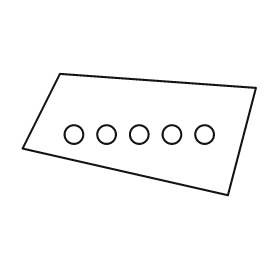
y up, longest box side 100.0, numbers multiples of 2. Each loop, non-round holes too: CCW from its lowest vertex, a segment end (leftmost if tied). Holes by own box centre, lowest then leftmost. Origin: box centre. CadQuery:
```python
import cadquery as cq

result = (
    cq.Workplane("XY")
    .moveTo(38.0, -26.0)
    .lineTo(50.0, 20.0)
    .lineTo(-34.0, 26.0)
    .lineTo(-50.0, -6.0)
    .close()
    .moveTo(-28.0, 0.0)
    .circle(4.0)
    .moveTo(-14.0, 0.0)
    .circle(4.0)
    .moveTo(0.0, 0.0)
    .circle(4.0)
    .moveTo(14.0, 0.0)
    .circle(4.0)
    .moveTo(28.0, 0.0)
    .circle(4.0)
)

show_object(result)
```